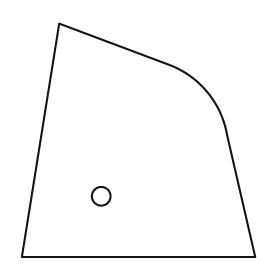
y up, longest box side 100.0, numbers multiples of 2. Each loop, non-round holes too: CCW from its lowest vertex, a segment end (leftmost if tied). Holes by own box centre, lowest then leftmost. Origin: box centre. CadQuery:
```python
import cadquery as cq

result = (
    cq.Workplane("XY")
    .moveTo(-50.0, -50.0)
    .lineTo(50.0, -50.0)
    .lineTo(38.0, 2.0)
    .threePointArc((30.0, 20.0), (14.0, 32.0))
    .lineTo(-34.0, 50.0)
    .close()
    .moveTo(-16.0, -24.0)
    .circle(4.0)
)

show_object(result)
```